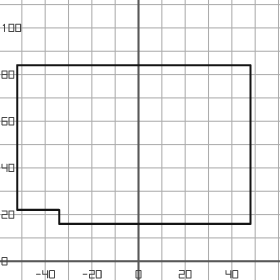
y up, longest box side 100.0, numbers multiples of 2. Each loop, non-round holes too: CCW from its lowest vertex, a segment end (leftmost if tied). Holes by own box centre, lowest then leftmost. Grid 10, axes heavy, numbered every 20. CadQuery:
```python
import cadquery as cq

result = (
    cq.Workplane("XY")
    .moveTo(-34.0, 16.0)
    .lineTo(48.0, 16.0)
    .lineTo(48.0, 84.0)
    .lineTo(-52.0, 84.0)
    .lineTo(-52.0, 22.0)
    .lineTo(-34.0, 22.0)
    .close()
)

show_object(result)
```